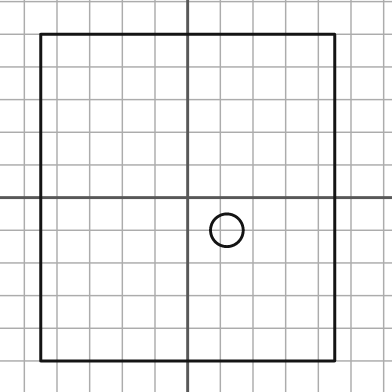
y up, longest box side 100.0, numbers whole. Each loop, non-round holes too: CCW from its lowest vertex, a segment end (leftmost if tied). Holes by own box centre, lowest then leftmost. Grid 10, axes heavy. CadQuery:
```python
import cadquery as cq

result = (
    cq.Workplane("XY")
    .moveTo(-45.0, -50.0)
    .lineTo(45.0, -50.0)
    .lineTo(45.0, 50.0)
    .lineTo(-45.0, 50.0)
    .close()
    .moveTo(12.0, -10.0)
    .circle(5.0)
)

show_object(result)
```